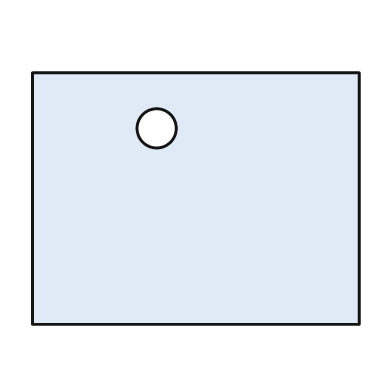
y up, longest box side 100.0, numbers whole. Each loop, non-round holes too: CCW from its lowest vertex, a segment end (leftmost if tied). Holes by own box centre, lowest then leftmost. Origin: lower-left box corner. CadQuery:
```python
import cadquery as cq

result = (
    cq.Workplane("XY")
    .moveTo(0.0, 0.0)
    .lineTo(100.0, 0.0)
    .lineTo(100.0, 77.0)
    .lineTo(0.0, 77.0)
    .close()
    .moveTo(38.0, 60.0)
    .circle(6.0)
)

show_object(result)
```